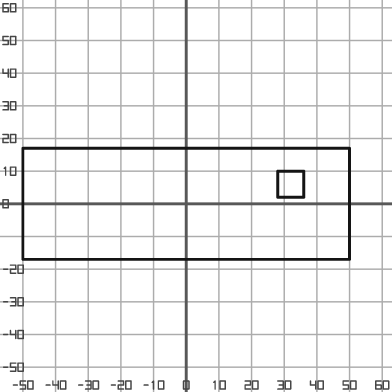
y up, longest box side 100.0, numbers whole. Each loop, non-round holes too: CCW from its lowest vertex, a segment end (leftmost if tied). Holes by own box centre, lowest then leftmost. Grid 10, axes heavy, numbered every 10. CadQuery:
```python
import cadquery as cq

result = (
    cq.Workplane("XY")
    .moveTo(-50.0, -17.0)
    .lineTo(50.0, -17.0)
    .lineTo(50.0, 17.0)
    .lineTo(-50.0, 17.0)
    .close()
    .moveTo(28.0, 2.0)
    .lineTo(36.0, 2.0)
    .lineTo(36.0, 10.0)
    .lineTo(28.0, 10.0)
    .close()
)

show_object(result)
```